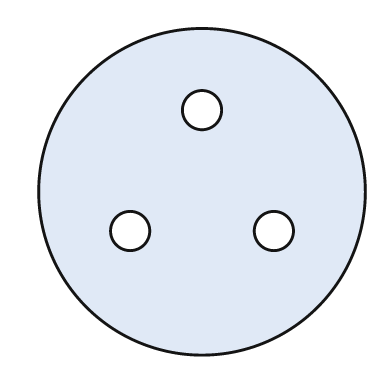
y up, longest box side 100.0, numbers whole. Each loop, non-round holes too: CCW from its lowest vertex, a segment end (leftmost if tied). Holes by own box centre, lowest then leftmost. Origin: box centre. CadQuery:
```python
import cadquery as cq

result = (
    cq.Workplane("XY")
    .moveTo(0.0, 0.0)
    .circle(50.0)
    .moveTo(-22.0, -12.0)
    .circle(6.0)
    .moveTo(22.0, -12.0)
    .circle(6.0)
    .moveTo(0.0, 25.0)
    .circle(6.0)
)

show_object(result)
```